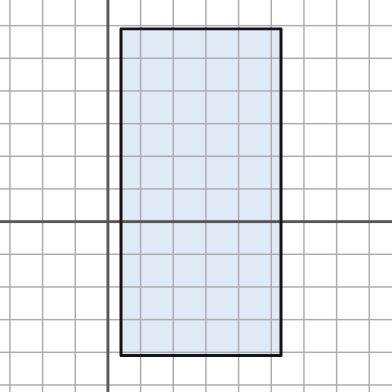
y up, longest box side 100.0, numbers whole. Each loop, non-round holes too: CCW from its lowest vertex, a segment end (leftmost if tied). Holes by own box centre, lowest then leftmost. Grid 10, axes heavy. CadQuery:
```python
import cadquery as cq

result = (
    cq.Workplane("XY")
    .moveTo(4.0, -41.0)
    .lineTo(53.0, -41.0)
    .lineTo(53.0, 59.0)
    .lineTo(4.0, 59.0)
    .close()
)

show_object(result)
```